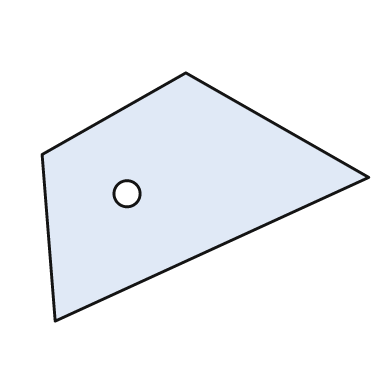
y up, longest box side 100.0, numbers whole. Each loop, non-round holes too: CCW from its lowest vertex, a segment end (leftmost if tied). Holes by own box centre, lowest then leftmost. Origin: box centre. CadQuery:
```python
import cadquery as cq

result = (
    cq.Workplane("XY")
    .moveTo(-46.0, -38.0)
    .lineTo(50.0, 6.0)
    .lineTo(-6.0, 38.0)
    .lineTo(-50.0, 13.0)
    .close()
    .moveTo(-24.0, 1.0)
    .circle(4.0)
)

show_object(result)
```